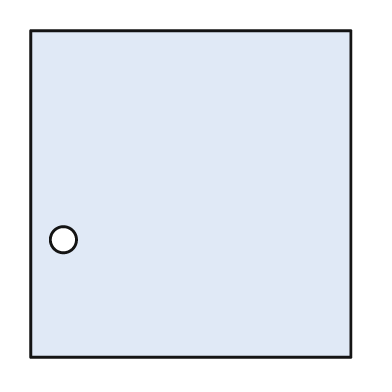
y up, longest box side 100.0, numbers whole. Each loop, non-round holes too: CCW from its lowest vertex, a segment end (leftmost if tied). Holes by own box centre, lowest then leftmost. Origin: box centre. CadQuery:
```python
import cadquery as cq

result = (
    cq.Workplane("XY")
    .moveTo(-49.0, -50.0)
    .lineTo(49.0, -50.0)
    .lineTo(49.0, 50.0)
    .lineTo(-49.0, 50.0)
    .close()
    .moveTo(-39.0, -14.0)
    .circle(4.0)
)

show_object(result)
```